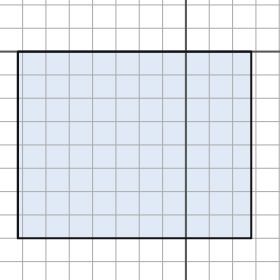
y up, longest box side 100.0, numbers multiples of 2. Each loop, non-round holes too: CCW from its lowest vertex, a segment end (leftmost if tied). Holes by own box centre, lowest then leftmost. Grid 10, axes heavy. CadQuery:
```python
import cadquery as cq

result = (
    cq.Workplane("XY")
    .moveTo(-72.0, -80.0)
    .lineTo(28.0, -80.0)
    .lineTo(28.0, 0.0)
    .lineTo(-72.0, 0.0)
    .close()
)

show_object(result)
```